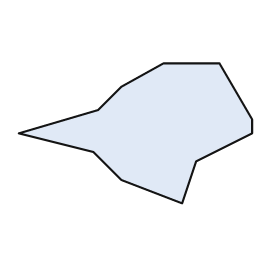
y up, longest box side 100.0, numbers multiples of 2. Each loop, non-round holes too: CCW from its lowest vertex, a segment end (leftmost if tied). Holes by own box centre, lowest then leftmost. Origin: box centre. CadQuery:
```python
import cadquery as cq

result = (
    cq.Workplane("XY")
    .moveTo(20.0, -30.0)
    .lineTo(26.0, -12.0)
    .lineTo(50.0, 0.0)
    .lineTo(50.0, 6.0)
    .lineTo(36.0, 30.0)
    .lineTo(12.0, 30.0)
    .lineTo(-6.0, 20.0)
    .lineTo(-16.0, 10.0)
    .lineTo(-50.0, 0.0)
    .lineTo(-18.0, -8.0)
    .lineTo(-6.0, -20.0)
    .close()
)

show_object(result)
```